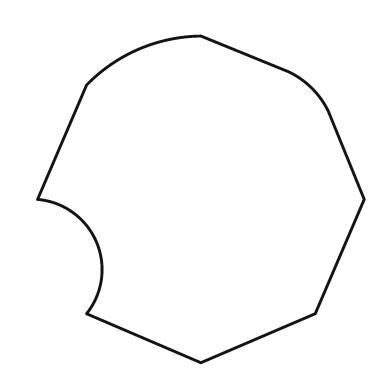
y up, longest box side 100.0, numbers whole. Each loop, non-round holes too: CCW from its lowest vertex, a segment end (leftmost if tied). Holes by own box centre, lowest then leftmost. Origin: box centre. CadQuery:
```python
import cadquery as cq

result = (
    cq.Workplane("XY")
    .moveTo(0.0, -50.0)
    .lineTo(35.0, -35.0)
    .lineTo(50.0, 0.0)
    .lineTo(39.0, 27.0)
    .threePointArc((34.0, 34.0), (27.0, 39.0))
    .lineTo(0.0, 50.0)
    .threePointArc((-19.0, 46.0), (-35.0, 35.0))
    .lineTo(-50.0, 0.0)
    .threePointArc((-32.0, -13.0), (-35.0, -35.0))
    .close()
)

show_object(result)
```